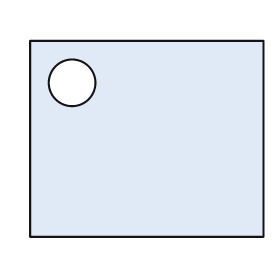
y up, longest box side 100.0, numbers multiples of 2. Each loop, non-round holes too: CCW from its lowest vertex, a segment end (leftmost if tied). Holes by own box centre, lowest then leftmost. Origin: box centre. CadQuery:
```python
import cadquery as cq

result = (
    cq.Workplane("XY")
    .moveTo(-50.0, -42.0)
    .lineTo(50.0, -42.0)
    .lineTo(50.0, 42.0)
    .lineTo(-50.0, 42.0)
    .close()
    .moveTo(-32.0, 24.0)
    .circle(10.0)
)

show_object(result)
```